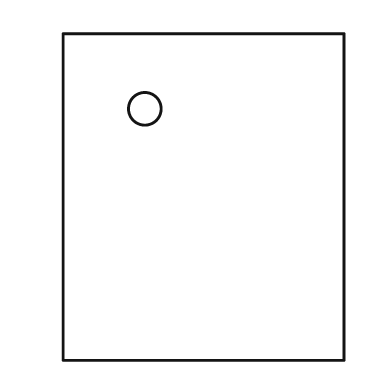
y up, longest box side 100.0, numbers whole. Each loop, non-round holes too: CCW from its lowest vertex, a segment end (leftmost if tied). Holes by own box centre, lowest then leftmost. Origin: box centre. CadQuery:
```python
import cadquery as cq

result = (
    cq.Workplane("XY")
    .moveTo(-43.0, -50.0)
    .lineTo(43.0, -50.0)
    .lineTo(43.0, 50.0)
    .lineTo(-43.0, 50.0)
    .close()
    .moveTo(-18.0, 27.0)
    .circle(5.0)
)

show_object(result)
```